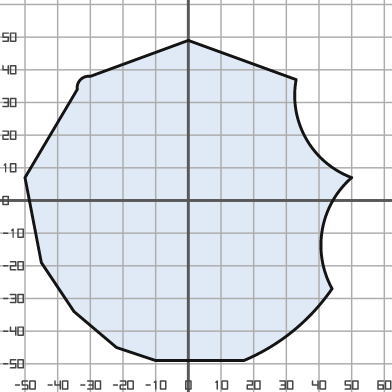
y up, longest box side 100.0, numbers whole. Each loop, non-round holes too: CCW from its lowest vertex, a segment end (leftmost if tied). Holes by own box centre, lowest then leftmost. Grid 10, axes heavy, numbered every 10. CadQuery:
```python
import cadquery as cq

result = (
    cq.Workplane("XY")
    .moveTo(-10.0, -49.0)
    .lineTo(17.0, -49.0)
    .threePointArc((32.0, -40.0), (44.0, -27.0))
    .threePointArc((41.0, -9.0), (50.0, 7.0))
    .threePointArc((36.0, 19.0), (33.0, 37.0))
    .lineTo(0.0, 49.0)
    .lineTo(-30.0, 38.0)
    .threePointArc((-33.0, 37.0), (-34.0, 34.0))
    .lineTo(-50.0, 7.0)
    .lineTo(-45.0, -19.0)
    .lineTo(-35.0, -34.0)
    .lineTo(-22.0, -45.0)
    .close()
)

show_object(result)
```